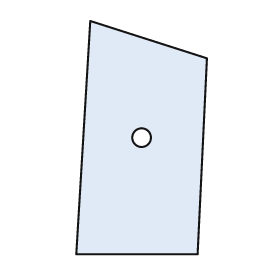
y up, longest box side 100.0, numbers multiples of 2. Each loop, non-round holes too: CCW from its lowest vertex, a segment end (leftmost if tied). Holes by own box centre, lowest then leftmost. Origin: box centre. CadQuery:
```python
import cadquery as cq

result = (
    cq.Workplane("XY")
    .moveTo(-28.0, -50.0)
    .lineTo(24.0, -50.0)
    .lineTo(28.0, 34.0)
    .lineTo(-22.0, 50.0)
    .close()
    .moveTo(0.0, 0.0)
    .circle(4.0)
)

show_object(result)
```